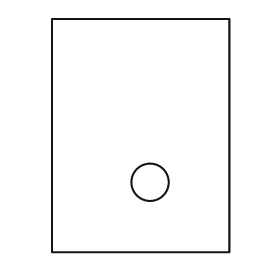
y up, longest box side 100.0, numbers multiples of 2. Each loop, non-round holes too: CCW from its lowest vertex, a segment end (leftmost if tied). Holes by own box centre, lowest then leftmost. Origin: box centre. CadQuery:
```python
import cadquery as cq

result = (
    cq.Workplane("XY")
    .moveTo(-38.0, -50.0)
    .lineTo(38.0, -50.0)
    .lineTo(38.0, 50.0)
    .lineTo(-38.0, 50.0)
    .close()
    .moveTo(4.0, -20.0)
    .circle(8.0)
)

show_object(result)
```